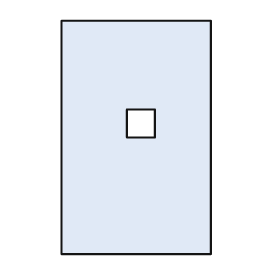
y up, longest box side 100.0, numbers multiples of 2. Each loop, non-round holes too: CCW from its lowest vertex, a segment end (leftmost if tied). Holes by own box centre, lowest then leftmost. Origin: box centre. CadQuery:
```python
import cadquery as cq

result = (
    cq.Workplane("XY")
    .moveTo(-32.0, -50.0)
    .lineTo(32.0, -50.0)
    .lineTo(32.0, 50.0)
    .lineTo(-32.0, 50.0)
    .close()
    .moveTo(-4.0, 0.0)
    .lineTo(8.0, 0.0)
    .lineTo(8.0, 12.0)
    .lineTo(-4.0, 12.0)
    .close()
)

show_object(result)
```